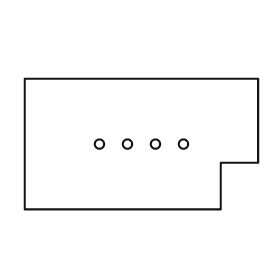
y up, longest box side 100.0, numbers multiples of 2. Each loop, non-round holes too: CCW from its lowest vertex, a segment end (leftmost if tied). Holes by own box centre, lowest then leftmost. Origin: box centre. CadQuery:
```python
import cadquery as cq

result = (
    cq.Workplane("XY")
    .moveTo(-50.0, -28.0)
    .lineTo(34.0, -28.0)
    .lineTo(34.0, -8.0)
    .lineTo(50.0, -8.0)
    .lineTo(50.0, 28.0)
    .lineTo(-50.0, 28.0)
    .close()
    .moveTo(-18.0, 0.0)
    .circle(2.0)
    .moveTo(-6.0, 0.0)
    .circle(2.0)
    .moveTo(6.0, 0.0)
    .circle(2.0)
    .moveTo(18.0, 0.0)
    .circle(2.0)
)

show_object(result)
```